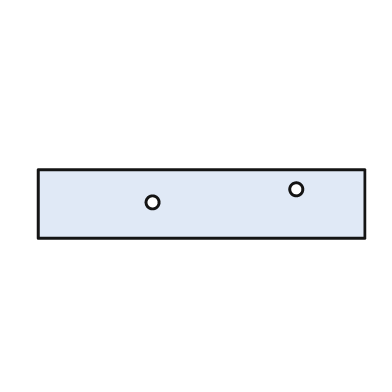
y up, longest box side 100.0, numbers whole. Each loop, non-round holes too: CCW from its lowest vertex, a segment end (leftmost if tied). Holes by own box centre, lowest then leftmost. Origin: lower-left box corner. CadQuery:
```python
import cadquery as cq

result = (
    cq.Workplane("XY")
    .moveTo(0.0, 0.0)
    .lineTo(100.0, 0.0)
    .lineTo(100.0, 21.0)
    .lineTo(0.0, 21.0)
    .close()
    .moveTo(35.0, 11.0)
    .circle(2.0)
    .moveTo(79.0, 15.0)
    .circle(2.0)
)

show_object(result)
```